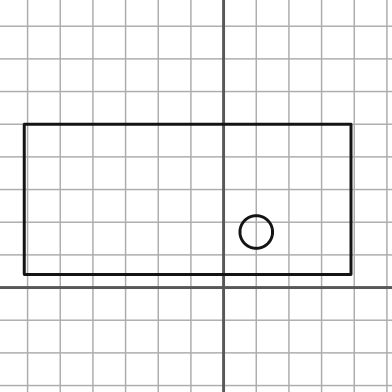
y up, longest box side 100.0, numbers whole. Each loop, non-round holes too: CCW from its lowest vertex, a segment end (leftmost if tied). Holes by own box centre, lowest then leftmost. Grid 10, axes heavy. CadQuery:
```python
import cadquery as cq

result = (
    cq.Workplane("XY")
    .moveTo(-61.0, 4.0)
    .lineTo(39.0, 4.0)
    .lineTo(39.0, 50.0)
    .lineTo(-61.0, 50.0)
    .close()
    .moveTo(10.0, 17.0)
    .circle(5.0)
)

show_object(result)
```